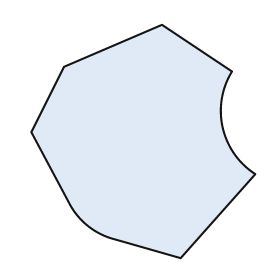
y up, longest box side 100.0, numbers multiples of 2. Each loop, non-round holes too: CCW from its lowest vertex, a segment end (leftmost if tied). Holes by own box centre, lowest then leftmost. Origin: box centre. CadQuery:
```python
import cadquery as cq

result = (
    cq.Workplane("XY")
    .moveTo(16.0, -50.0)
    .lineTo(48.0, -14.0)
    .threePointArc((34.0, 6.0), (38.0, 30.0))
    .lineTo(8.0, 50.0)
    .lineTo(-34.0, 32.0)
    .lineTo(-48.0, 4.0)
    .lineTo(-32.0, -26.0)
    .threePointArc((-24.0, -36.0), (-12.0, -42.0))
    .close()
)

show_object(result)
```